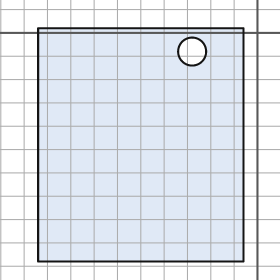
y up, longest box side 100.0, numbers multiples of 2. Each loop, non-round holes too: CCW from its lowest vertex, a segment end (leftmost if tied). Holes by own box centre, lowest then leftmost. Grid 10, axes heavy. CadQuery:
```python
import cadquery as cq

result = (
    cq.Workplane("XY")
    .moveTo(-94.0, -98.0)
    .lineTo(-6.0, -98.0)
    .lineTo(-6.0, 2.0)
    .lineTo(-94.0, 2.0)
    .close()
    .moveTo(-28.0, -8.0)
    .circle(6.0)
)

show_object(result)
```